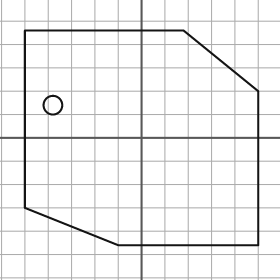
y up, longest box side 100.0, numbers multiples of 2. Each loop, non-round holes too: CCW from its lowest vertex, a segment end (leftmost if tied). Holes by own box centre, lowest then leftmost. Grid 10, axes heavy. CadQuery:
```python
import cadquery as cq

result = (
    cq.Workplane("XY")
    .moveTo(-10.0, -46.0)
    .lineTo(50.0, -46.0)
    .lineTo(50.0, 20.0)
    .lineTo(18.0, 46.0)
    .lineTo(-50.0, 46.0)
    .lineTo(-50.0, -30.0)
    .close()
    .moveTo(-38.0, 14.0)
    .circle(4.0)
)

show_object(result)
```